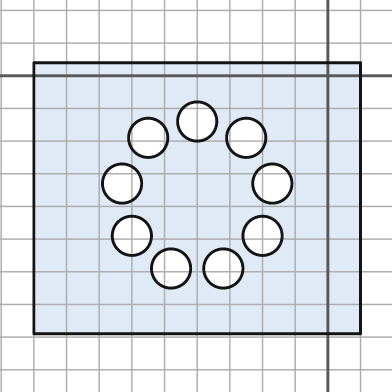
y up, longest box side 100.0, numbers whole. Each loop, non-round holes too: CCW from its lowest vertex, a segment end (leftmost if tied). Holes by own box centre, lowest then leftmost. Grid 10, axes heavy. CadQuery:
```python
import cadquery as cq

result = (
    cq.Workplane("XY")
    .moveTo(-90.0, -79.0)
    .lineTo(10.0, -79.0)
    .lineTo(10.0, 4.0)
    .lineTo(-90.0, 4.0)
    .close()
    .moveTo(-48.0, -59.0)
    .circle(6.0)
    .moveTo(-32.0, -59.0)
    .circle(6.0)
    .moveTo(-60.0, -49.0)
    .circle(6.0)
    .moveTo(-20.0, -49.0)
    .circle(6.0)
    .moveTo(-63.0, -33.0)
    .circle(6.0)
    .moveTo(-17.0, -33.0)
    .circle(6.0)
    .moveTo(-55.0, -19.0)
    .circle(6.0)
    .moveTo(-25.0, -19.0)
    .circle(6.0)
    .moveTo(-40.0, -14.0)
    .circle(6.0)
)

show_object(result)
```